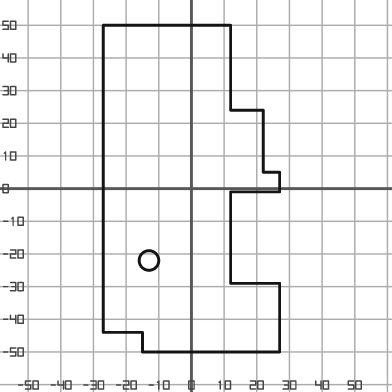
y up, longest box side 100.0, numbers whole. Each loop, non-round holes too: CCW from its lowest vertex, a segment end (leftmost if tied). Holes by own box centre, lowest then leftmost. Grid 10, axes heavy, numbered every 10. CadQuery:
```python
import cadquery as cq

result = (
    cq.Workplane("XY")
    .moveTo(-15.0, -50.0)
    .lineTo(27.0, -50.0)
    .lineTo(27.0, -29.0)
    .lineTo(12.0, -29.0)
    .lineTo(12.0, -1.0)
    .lineTo(27.0, -1.0)
    .lineTo(27.0, 5.0)
    .lineTo(22.0, 5.0)
    .lineTo(22.0, 24.0)
    .lineTo(12.0, 24.0)
    .lineTo(12.0, 50.0)
    .lineTo(-27.0, 50.0)
    .lineTo(-27.0, -44.0)
    .lineTo(-15.0, -44.0)
    .close()
    .moveTo(-13.0, -22.0)
    .circle(3.0)
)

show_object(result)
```